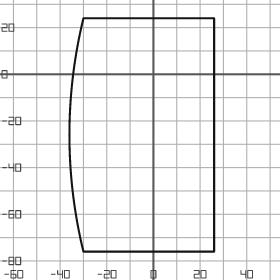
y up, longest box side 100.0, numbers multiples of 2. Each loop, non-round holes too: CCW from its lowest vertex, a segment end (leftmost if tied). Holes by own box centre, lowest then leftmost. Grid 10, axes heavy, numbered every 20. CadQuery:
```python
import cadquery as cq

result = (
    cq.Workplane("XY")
    .moveTo(-30.0, -76.0)
    .lineTo(26.0, -76.0)
    .lineTo(26.0, 24.0)
    .lineTo(-30.0, 24.0)
    .threePointArc((-36.0, -26.0), (-30.0, -76.0))
    .close()
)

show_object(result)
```